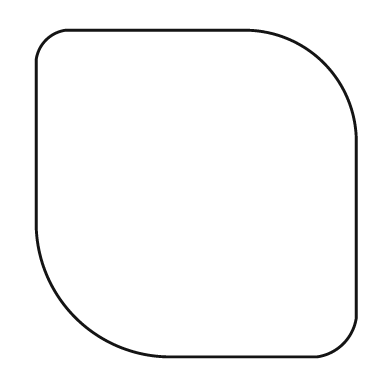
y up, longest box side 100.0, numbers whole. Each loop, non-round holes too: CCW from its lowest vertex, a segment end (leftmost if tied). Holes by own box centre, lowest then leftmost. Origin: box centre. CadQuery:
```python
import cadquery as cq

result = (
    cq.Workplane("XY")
    .moveTo(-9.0, -50.0)
    .lineTo(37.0, -50.0)
    .threePointArc((45.0, -46.0), (49.0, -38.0))
    .lineTo(49.0, 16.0)
    .threePointArc((39.0, 40.0), (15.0, 50.0))
    .lineTo(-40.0, 50.0)
    .threePointArc((-46.0, 47.0), (-49.0, 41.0))
    .lineTo(-49.0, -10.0)
    .threePointArc((-37.0, -38.0), (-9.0, -50.0))
    .close()
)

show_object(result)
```